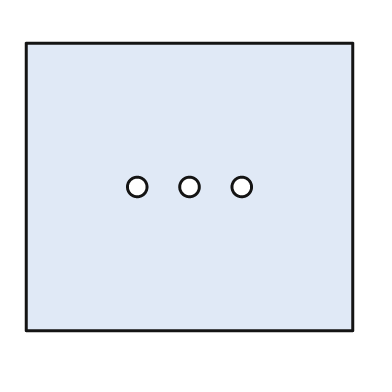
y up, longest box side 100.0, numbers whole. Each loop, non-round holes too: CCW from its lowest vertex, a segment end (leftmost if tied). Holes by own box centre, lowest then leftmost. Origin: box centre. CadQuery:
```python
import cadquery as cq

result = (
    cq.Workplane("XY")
    .moveTo(-50.0, -44.0)
    .lineTo(50.0, -44.0)
    .lineTo(50.0, 44.0)
    .lineTo(-50.0, 44.0)
    .close()
    .moveTo(-16.0, 0.0)
    .circle(3.0)
    .moveTo(0.0, 0.0)
    .circle(3.0)
    .moveTo(16.0, 0.0)
    .circle(3.0)
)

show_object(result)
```